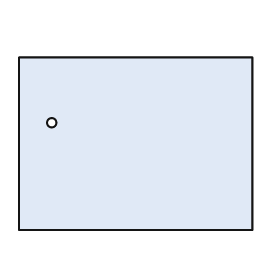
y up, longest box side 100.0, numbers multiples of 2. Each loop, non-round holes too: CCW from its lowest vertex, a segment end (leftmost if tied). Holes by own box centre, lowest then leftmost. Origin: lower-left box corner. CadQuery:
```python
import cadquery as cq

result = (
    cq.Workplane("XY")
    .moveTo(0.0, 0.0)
    .lineTo(100.0, 0.0)
    .lineTo(100.0, 74.0)
    .lineTo(0.0, 74.0)
    .close()
    .moveTo(14.0, 46.0)
    .circle(2.0)
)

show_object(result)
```